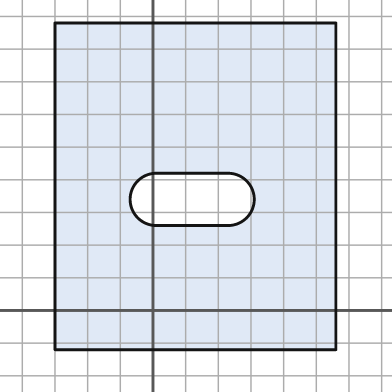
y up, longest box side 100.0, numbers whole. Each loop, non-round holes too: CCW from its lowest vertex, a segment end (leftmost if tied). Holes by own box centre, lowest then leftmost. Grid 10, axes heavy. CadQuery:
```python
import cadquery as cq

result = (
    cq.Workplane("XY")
    .moveTo(-30.0, -12.0)
    .lineTo(56.0, -12.0)
    .lineTo(56.0, 88.0)
    .lineTo(-30.0, 88.0)
    .close()
    .moveTo(1.0, 26.0)
    .lineTo(23.0, 26.0)
    .threePointArc((31.0, 34.0), (23.0, 42.0))
    .lineTo(1.0, 42.0)
    .threePointArc((-7.0, 34.0), (1.0, 26.0))
    .close()
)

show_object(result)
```